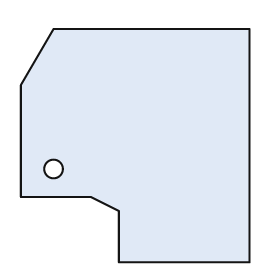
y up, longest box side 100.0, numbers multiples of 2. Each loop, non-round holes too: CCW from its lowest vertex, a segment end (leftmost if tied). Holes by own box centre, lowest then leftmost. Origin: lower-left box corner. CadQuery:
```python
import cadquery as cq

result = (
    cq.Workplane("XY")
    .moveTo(42.0, 0.0)
    .lineTo(98.0, 0.0)
    .lineTo(98.0, 100.0)
    .lineTo(14.0, 100.0)
    .lineTo(0.0, 76.0)
    .lineTo(0.0, 28.0)
    .lineTo(30.0, 28.0)
    .lineTo(42.0, 22.0)
    .close()
    .moveTo(14.0, 40.0)
    .circle(4.0)
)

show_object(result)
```